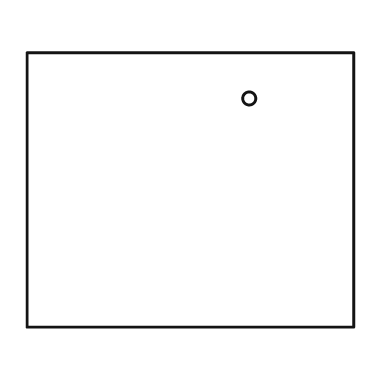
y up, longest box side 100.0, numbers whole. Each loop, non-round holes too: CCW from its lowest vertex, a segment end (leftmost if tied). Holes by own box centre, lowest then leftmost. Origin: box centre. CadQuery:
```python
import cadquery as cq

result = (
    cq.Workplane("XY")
    .moveTo(-50.0, -42.0)
    .lineTo(50.0, -42.0)
    .lineTo(50.0, 42.0)
    .lineTo(-50.0, 42.0)
    .close()
    .moveTo(18.0, 28.0)
    .circle(2.0)
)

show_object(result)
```